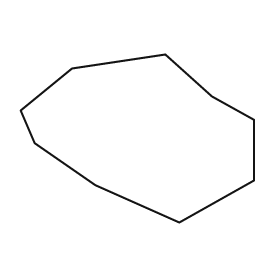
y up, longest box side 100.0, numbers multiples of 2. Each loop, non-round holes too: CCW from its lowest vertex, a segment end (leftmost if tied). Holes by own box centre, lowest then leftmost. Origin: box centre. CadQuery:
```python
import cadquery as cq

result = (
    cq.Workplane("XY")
    .moveTo(18.0, -36.0)
    .lineTo(50.0, -18.0)
    .lineTo(50.0, 8.0)
    .lineTo(32.0, 18.0)
    .lineTo(12.0, 36.0)
    .lineTo(-28.0, 30.0)
    .lineTo(-50.0, 12.0)
    .lineTo(-44.0, -2.0)
    .lineTo(-18.0, -20.0)
    .close()
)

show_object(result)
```